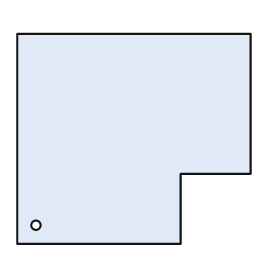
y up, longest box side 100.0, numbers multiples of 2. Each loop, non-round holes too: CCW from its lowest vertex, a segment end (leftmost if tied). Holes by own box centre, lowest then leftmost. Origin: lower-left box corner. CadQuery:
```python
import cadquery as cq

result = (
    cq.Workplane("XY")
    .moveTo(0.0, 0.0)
    .lineTo(70.0, 0.0)
    .lineTo(70.0, 30.0)
    .lineTo(100.0, 30.0)
    .lineTo(100.0, 90.0)
    .lineTo(0.0, 90.0)
    .close()
    .moveTo(8.0, 8.0)
    .circle(2.0)
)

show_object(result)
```